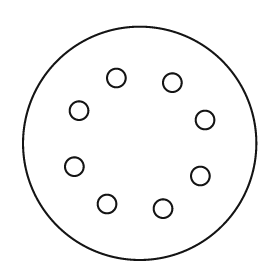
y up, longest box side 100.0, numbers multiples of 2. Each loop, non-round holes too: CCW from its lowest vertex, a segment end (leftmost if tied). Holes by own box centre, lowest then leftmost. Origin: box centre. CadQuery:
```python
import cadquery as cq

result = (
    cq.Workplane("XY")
    .moveTo(0.0, 0.0)
    .circle(50.0)
    .moveTo(10.0, -28.0)
    .circle(4.0)
    .moveTo(-14.0, -26.0)
    .circle(4.0)
    .moveTo(26.0, -14.0)
    .circle(4.0)
    .moveTo(-28.0, -10.0)
    .circle(4.0)
    .moveTo(28.0, 10.0)
    .circle(4.0)
    .moveTo(-26.0, 14.0)
    .circle(4.0)
    .moveTo(14.0, 26.0)
    .circle(4.0)
    .moveTo(-10.0, 28.0)
    .circle(4.0)
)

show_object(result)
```